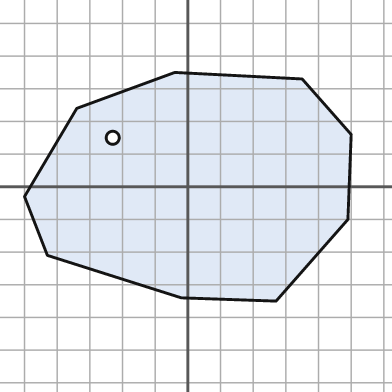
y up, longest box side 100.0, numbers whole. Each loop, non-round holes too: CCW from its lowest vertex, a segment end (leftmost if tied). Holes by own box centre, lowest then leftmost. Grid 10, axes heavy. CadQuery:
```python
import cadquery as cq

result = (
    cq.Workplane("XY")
    .moveTo(27.0, -35.0)
    .lineTo(49.0, -10.0)
    .lineTo(50.0, 16.0)
    .lineTo(35.0, 33.0)
    .lineTo(-4.0, 35.0)
    .lineTo(-34.0, 24.0)
    .lineTo(-50.0, -3.0)
    .lineTo(-43.0, -21.0)
    .lineTo(-2.0, -34.0)
    .close()
    .moveTo(-23.0, 15.0)
    .circle(2.0)
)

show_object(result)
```